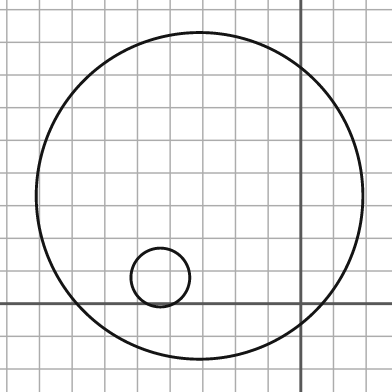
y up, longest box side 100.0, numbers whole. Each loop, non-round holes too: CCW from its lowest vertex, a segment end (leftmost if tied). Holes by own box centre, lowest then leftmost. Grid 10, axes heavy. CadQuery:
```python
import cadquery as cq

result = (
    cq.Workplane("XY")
    .moveTo(-31.0, 33.0)
    .circle(50.0)
    .moveTo(-43.0, 8.0)
    .circle(9.0)
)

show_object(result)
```